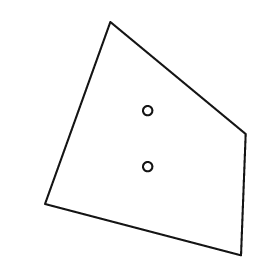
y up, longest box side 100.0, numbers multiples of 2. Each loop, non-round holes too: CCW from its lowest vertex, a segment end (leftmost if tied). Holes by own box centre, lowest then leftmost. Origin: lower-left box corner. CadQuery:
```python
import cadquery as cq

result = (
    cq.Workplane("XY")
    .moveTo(84.0, 0.0)
    .lineTo(86.0, 52.0)
    .lineTo(28.0, 100.0)
    .lineTo(0.0, 22.0)
    .close()
    .moveTo(44.0, 38.0)
    .circle(2.0)
    .moveTo(44.0, 62.0)
    .circle(2.0)
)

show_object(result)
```